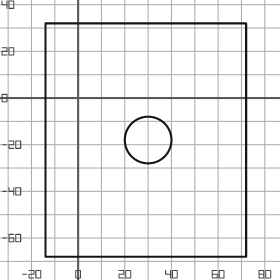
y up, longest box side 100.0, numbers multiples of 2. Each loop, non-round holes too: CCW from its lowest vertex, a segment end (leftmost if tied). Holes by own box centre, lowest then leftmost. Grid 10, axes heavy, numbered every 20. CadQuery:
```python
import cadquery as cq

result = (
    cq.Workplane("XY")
    .moveTo(-14.0, -68.0)
    .lineTo(72.0, -68.0)
    .lineTo(72.0, 32.0)
    .lineTo(-14.0, 32.0)
    .close()
    .moveTo(30.0, -18.0)
    .circle(10.0)
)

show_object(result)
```